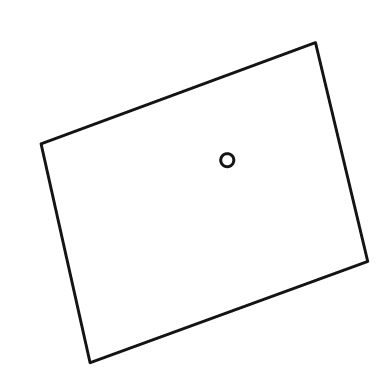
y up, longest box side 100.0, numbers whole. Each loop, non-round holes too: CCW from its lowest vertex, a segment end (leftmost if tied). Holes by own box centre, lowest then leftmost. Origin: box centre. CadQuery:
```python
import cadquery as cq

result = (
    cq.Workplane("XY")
    .moveTo(-35.0, -49.0)
    .lineTo(50.0, -18.0)
    .lineTo(34.0, 49.0)
    .lineTo(-50.0, 18.0)
    .close()
    .moveTo(7.0, 13.0)
    .circle(2.0)
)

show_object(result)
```